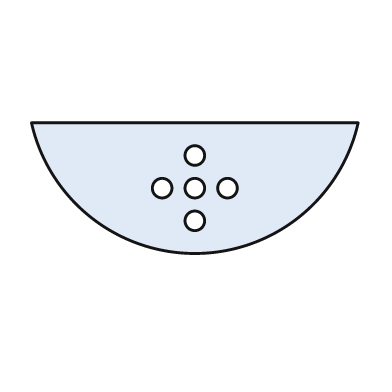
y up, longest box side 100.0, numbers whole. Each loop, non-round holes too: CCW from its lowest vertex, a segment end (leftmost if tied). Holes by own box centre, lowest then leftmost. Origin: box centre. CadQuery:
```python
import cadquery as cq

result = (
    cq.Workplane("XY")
    .moveTo(-50.0, 20.0)
    .threePointArc((0.0, -20.0), (50.0, 20.0))
    .close()
    .moveTo(0.0, -10.0)
    .circle(3.0)
    .moveTo(-10.0, 0.0)
    .circle(3.0)
    .moveTo(0.0, 0.0)
    .circle(3.0)
    .moveTo(10.0, 0.0)
    .circle(3.0)
    .moveTo(0.0, 10.0)
    .circle(3.0)
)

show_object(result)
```